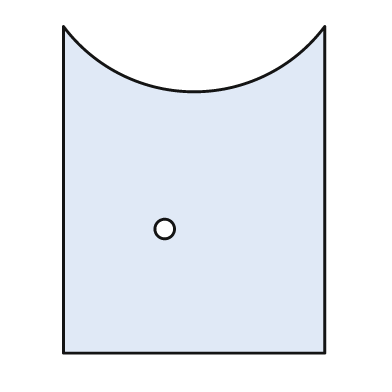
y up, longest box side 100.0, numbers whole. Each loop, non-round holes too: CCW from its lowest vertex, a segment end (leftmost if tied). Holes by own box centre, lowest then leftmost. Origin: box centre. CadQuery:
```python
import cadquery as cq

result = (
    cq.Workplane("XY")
    .moveTo(-40.0, -50.0)
    .lineTo(40.0, -50.0)
    .lineTo(40.0, 50.0)
    .threePointArc((0.0, 30.0), (-40.0, 50.0))
    .close()
    .moveTo(-9.0, -12.0)
    .circle(3.0)
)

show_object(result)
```